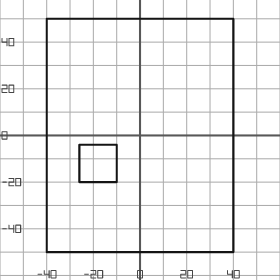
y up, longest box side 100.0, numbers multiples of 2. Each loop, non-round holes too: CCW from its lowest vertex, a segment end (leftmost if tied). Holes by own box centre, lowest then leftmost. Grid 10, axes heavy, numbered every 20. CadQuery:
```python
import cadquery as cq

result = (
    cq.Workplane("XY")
    .moveTo(-40.0, -50.0)
    .lineTo(40.0, -50.0)
    .lineTo(40.0, 50.0)
    .lineTo(-40.0, 50.0)
    .close()
    .moveTo(-26.0, -20.0)
    .lineTo(-10.0, -20.0)
    .lineTo(-10.0, -4.0)
    .lineTo(-26.0, -4.0)
    .close()
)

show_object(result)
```